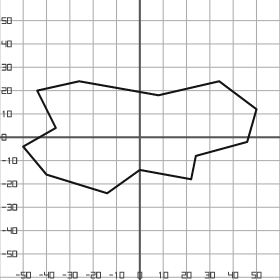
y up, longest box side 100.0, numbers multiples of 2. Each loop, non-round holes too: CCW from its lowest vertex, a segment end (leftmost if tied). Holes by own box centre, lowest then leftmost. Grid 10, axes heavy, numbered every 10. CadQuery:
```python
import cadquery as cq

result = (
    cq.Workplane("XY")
    .moveTo(-14.0, -24.0)
    .lineTo(0.0, -14.0)
    .lineTo(22.0, -18.0)
    .lineTo(24.0, -8.0)
    .lineTo(46.0, -2.0)
    .lineTo(50.0, 12.0)
    .lineTo(34.0, 24.0)
    .lineTo(8.0, 18.0)
    .lineTo(-26.0, 24.0)
    .lineTo(-44.0, 20.0)
    .lineTo(-36.0, 4.0)
    .lineTo(-50.0, -4.0)
    .lineTo(-40.0, -16.0)
    .close()
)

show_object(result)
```